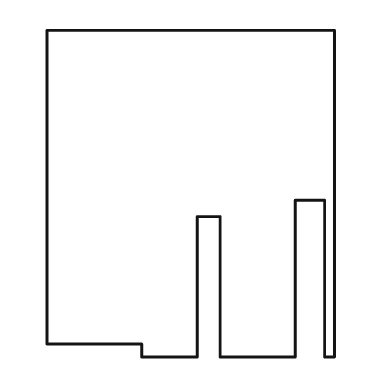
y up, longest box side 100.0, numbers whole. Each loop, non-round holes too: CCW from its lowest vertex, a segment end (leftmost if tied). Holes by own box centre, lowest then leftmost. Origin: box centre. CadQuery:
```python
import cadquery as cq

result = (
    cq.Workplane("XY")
    .moveTo(-15.0, -50.0)
    .lineTo(2.0, -50.0)
    .lineTo(2.0, -7.0)
    .lineTo(9.0, -7.0)
    .lineTo(9.0, -50.0)
    .lineTo(32.0, -50.0)
    .lineTo(32.0, -2.0)
    .lineTo(41.0, -2.0)
    .lineTo(41.0, -50.0)
    .lineTo(44.0, -50.0)
    .lineTo(44.0, 50.0)
    .lineTo(-44.0, 50.0)
    .lineTo(-44.0, -46.0)
    .lineTo(-15.0, -46.0)
    .close()
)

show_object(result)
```